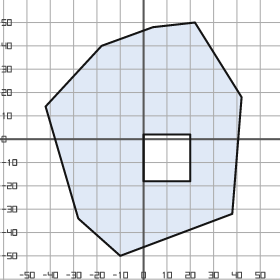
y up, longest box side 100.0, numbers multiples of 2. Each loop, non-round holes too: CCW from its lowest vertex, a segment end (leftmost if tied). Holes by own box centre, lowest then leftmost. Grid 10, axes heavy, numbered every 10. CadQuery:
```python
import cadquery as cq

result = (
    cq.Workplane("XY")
    .moveTo(-10.0, -50.0)
    .lineTo(38.0, -32.0)
    .lineTo(42.0, 18.0)
    .lineTo(22.0, 50.0)
    .lineTo(4.0, 48.0)
    .lineTo(-18.0, 40.0)
    .lineTo(-42.0, 14.0)
    .lineTo(-28.0, -34.0)
    .close()
    .moveTo(0.0, -18.0)
    .lineTo(20.0, -18.0)
    .lineTo(20.0, 2.0)
    .lineTo(0.0, 2.0)
    .close()
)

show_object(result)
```